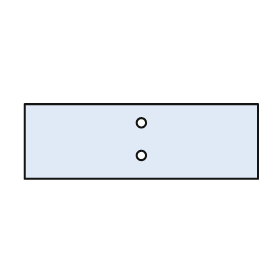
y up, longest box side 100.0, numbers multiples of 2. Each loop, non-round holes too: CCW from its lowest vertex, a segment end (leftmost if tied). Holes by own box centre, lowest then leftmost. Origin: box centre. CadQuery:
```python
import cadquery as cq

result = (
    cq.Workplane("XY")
    .moveTo(-50.0, -16.0)
    .lineTo(50.0, -16.0)
    .lineTo(50.0, 16.0)
    .lineTo(-50.0, 16.0)
    .close()
    .moveTo(0.0, -6.0)
    .circle(2.0)
    .moveTo(0.0, 8.0)
    .circle(2.0)
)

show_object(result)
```